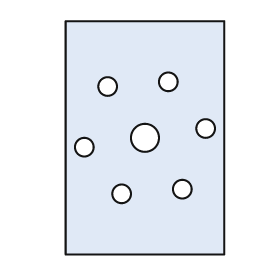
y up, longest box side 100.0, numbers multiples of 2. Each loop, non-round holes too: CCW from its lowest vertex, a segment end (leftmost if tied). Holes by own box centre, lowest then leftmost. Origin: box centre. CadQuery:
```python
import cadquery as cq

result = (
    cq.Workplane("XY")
    .moveTo(-34.0, -50.0)
    .lineTo(34.0, -50.0)
    .lineTo(34.0, 50.0)
    .lineTo(-34.0, 50.0)
    .close()
    .moveTo(-10.0, -24.0)
    .circle(4.0)
    .moveTo(16.0, -22.0)
    .circle(4.0)
    .moveTo(-26.0, -4.0)
    .circle(4.0)
    .moveTo(0.0, 0.0)
    .circle(6.0)
    .moveTo(26.0, 4.0)
    .circle(4.0)
    .moveTo(-16.0, 22.0)
    .circle(4.0)
    .moveTo(10.0, 24.0)
    .circle(4.0)
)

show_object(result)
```